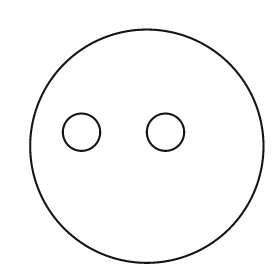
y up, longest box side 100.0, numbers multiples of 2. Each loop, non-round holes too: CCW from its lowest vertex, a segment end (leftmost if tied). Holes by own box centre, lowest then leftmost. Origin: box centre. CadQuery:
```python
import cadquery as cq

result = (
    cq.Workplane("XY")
    .moveTo(0.0, 0.0)
    .circle(50.0)
    .moveTo(-28.0, 6.0)
    .circle(8.0)
    .moveTo(8.0, 6.0)
    .circle(8.0)
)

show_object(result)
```